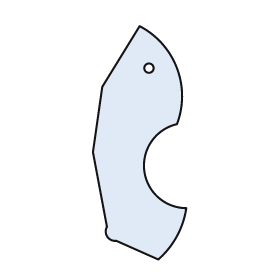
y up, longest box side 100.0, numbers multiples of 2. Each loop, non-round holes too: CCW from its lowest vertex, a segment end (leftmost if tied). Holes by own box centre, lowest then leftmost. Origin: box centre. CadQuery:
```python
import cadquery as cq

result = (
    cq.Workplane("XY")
    .moveTo(8.0, -50.0)
    .threePointArc((16.0, -40.0), (20.0, -28.0))
    .threePointArc((2.0, -12.0), (16.0, 8.0))
    .threePointArc((16.0, 32.0), (0.0, 50.0))
    .lineTo(-16.0, 24.0)
    .lineTo(-20.0, -4.0)
    .lineTo(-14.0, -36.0)
    .threePointArc((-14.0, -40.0), (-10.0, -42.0))
    .close()
    .moveTo(4.0, 32.0)
    .circle(2.0)
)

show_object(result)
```